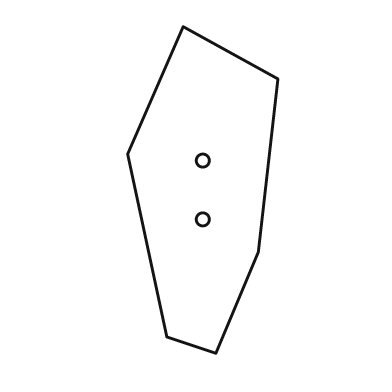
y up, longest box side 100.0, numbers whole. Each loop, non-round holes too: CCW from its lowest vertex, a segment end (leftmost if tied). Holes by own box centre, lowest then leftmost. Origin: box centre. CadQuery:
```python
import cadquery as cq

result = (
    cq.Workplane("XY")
    .moveTo(4.0, -50.0)
    .lineTo(17.0, -19.0)
    .lineTo(23.0, 34.0)
    .lineTo(-6.0, 50.0)
    .lineTo(-23.0, 11.0)
    .lineTo(-11.0, -45.0)
    .close()
    .moveTo(0.0, -9.0)
    .circle(2.0)
    .moveTo(0.0, 9.0)
    .circle(2.0)
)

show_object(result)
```